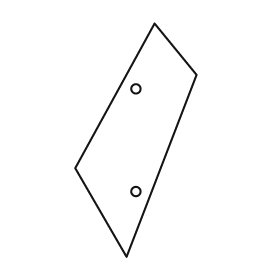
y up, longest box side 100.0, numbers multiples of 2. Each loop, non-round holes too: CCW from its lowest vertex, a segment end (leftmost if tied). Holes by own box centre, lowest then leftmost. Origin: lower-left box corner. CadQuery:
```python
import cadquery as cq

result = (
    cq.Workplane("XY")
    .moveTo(22.0, 0.0)
    .lineTo(52.0, 78.0)
    .lineTo(34.0, 100.0)
    .lineTo(0.0, 38.0)
    .close()
    .moveTo(26.0, 28.0)
    .circle(2.0)
    .moveTo(26.0, 72.0)
    .circle(2.0)
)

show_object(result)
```